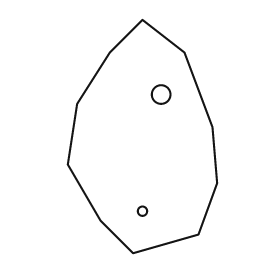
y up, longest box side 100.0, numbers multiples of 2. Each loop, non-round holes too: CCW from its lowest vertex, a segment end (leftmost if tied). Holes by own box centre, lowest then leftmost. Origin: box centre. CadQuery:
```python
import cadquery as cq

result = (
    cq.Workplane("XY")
    .moveTo(-4.0, -50.0)
    .lineTo(24.0, -42.0)
    .lineTo(32.0, -20.0)
    .lineTo(30.0, 4.0)
    .lineTo(18.0, 36.0)
    .lineTo(0.0, 50.0)
    .lineTo(-14.0, 36.0)
    .lineTo(-28.0, 14.0)
    .lineTo(-32.0, -12.0)
    .lineTo(-18.0, -36.0)
    .close()
    .moveTo(0.0, -32.0)
    .circle(2.0)
    .moveTo(8.0, 18.0)
    .circle(4.0)
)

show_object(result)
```